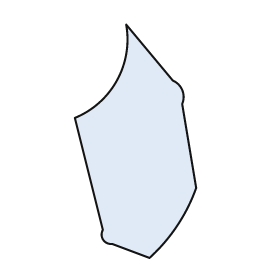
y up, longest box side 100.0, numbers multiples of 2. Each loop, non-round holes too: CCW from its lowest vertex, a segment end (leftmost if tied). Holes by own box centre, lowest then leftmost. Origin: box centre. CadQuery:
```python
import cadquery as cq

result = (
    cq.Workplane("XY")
    .moveTo(6.0, -50.0)
    .threePointArc((18.0, -36.0), (26.0, -20.0))
    .lineTo(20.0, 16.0)
    .threePointArc((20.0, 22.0), (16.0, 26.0))
    .lineTo(-4.0, 50.0)
    .threePointArc((-8.0, 26.0), (-26.0, 10.0))
    .lineTo(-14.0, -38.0)
    .threePointArc((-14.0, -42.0), (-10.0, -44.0))
    .close()
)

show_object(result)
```